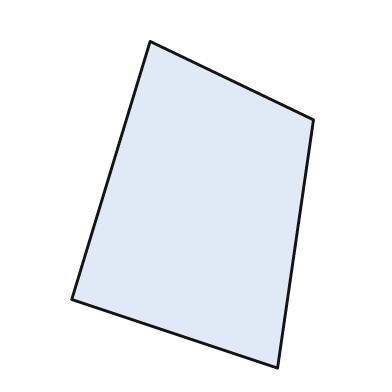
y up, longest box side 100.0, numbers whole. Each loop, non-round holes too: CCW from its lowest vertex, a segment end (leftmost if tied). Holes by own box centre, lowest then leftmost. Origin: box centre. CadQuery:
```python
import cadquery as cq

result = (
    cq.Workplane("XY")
    .moveTo(26.0, -50.0)
    .lineTo(37.0, 26.0)
    .lineTo(-13.0, 50.0)
    .lineTo(-37.0, -29.0)
    .close()
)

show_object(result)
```